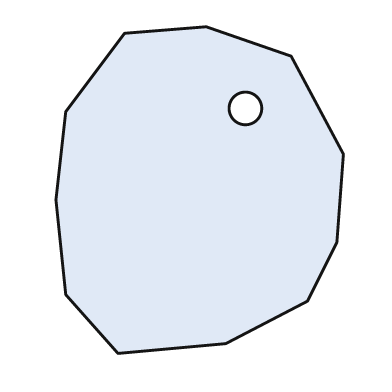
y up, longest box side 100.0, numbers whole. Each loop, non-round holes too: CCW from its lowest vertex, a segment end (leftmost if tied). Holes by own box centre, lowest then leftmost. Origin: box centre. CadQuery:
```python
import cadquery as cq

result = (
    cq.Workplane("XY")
    .moveTo(-25.0, -50.0)
    .lineTo(8.0, -47.0)
    .lineTo(33.0, -34.0)
    .lineTo(42.0, -16.0)
    .lineTo(44.0, 11.0)
    .lineTo(28.0, 41.0)
    .lineTo(2.0, 50.0)
    .lineTo(-23.0, 48.0)
    .lineTo(-41.0, 24.0)
    .lineTo(-44.0, -3.0)
    .lineTo(-41.0, -32.0)
    .close()
    .moveTo(14.0, 25.0)
    .circle(5.0)
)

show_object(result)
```